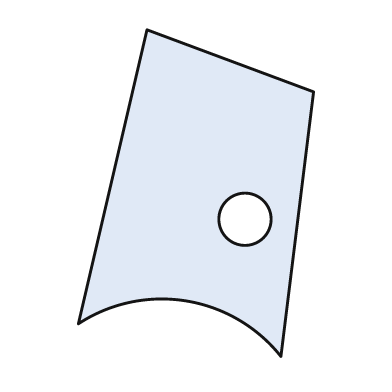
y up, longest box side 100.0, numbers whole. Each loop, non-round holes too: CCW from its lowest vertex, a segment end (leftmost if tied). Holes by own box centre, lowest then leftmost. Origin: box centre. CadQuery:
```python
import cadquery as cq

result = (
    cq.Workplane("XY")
    .moveTo(26.0, -50.0)
    .lineTo(36.0, 31.0)
    .lineTo(-15.0, 50.0)
    .lineTo(-36.0, -40.0)
    .threePointArc((-3.0, -33.0), (26.0, -50.0))
    .close()
    .moveTo(15.0, -8.0)
    .circle(8.0)
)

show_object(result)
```